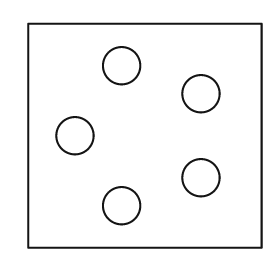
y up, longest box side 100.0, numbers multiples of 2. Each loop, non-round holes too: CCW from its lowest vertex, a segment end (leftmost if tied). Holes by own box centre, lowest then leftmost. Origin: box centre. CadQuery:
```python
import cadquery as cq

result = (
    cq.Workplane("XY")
    .moveTo(-50.0, -48.0)
    .lineTo(50.0, -48.0)
    .lineTo(50.0, 48.0)
    .lineTo(-50.0, 48.0)
    .close()
    .moveTo(-10.0, -30.0)
    .circle(8.0)
    .moveTo(24.0, -18.0)
    .circle(8.0)
    .moveTo(-30.0, 0.0)
    .circle(8.0)
    .moveTo(24.0, 18.0)
    .circle(8.0)
    .moveTo(-10.0, 30.0)
    .circle(8.0)
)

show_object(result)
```